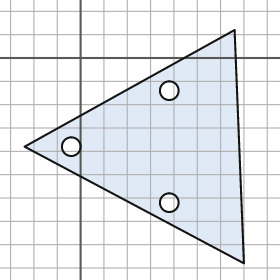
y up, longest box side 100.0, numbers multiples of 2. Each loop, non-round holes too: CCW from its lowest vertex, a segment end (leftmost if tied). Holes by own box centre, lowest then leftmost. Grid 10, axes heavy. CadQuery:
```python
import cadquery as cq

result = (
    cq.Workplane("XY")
    .moveTo(70.0, -88.0)
    .lineTo(66.0, 12.0)
    .lineTo(-24.0, -38.0)
    .close()
    .moveTo(38.0, -62.0)
    .circle(4.0)
    .moveTo(-4.0, -38.0)
    .circle(4.0)
    .moveTo(38.0, -14.0)
    .circle(4.0)
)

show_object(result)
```